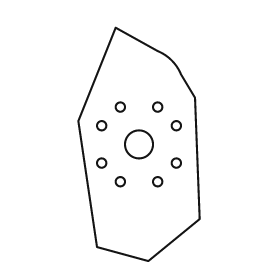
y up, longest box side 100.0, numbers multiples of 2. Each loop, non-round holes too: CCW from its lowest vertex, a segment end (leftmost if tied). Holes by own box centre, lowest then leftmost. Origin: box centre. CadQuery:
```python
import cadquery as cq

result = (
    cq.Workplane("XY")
    .moveTo(4.0, -50.0)
    .lineTo(26.0, -32.0)
    .lineTo(24.0, 20.0)
    .lineTo(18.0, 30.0)
    .threePointArc((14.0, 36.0), (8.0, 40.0))
    .lineTo(-10.0, 50.0)
    .lineTo(-26.0, 10.0)
    .lineTo(-18.0, -44.0)
    .close()
    .moveTo(-8.0, -16.0)
    .circle(2.0)
    .moveTo(8.0, -16.0)
    .circle(2.0)
    .moveTo(-16.0, -8.0)
    .circle(2.0)
    .moveTo(16.0, -8.0)
    .circle(2.0)
    .moveTo(0.0, 0.0)
    .circle(6.0)
    .moveTo(-16.0, 8.0)
    .circle(2.0)
    .moveTo(16.0, 8.0)
    .circle(2.0)
    .moveTo(-8.0, 16.0)
    .circle(2.0)
    .moveTo(8.0, 16.0)
    .circle(2.0)
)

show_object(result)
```